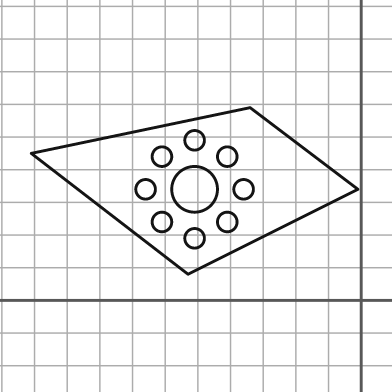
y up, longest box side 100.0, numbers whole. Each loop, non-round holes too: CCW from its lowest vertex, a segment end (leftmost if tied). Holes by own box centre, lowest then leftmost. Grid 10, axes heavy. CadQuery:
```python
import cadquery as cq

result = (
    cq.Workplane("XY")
    .moveTo(-53.0, 8.0)
    .lineTo(-1.0, 34.0)
    .lineTo(-34.0, 59.0)
    .lineTo(-101.0, 45.0)
    .close()
    .moveTo(-51.0, 19.0)
    .circle(3.0)
    .moveTo(-61.0, 24.0)
    .circle(3.0)
    .moveTo(-41.0, 24.0)
    .circle(3.0)
    .moveTo(-66.0, 34.0)
    .circle(3.0)
    .moveTo(-51.0, 34.0)
    .circle(7.0)
    .moveTo(-36.0, 34.0)
    .circle(3.0)
    .moveTo(-61.0, 44.0)
    .circle(3.0)
    .moveTo(-41.0, 44.0)
    .circle(3.0)
    .moveTo(-51.0, 49.0)
    .circle(3.0)
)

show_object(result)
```